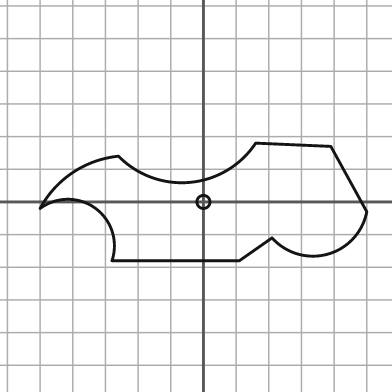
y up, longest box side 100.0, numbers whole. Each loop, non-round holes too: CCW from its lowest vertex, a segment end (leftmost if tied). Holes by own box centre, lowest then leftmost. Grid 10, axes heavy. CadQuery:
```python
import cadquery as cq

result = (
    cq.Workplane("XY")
    .moveTo(-28.0, -18.0)
    .lineTo(11.0, -18.0)
    .lineTo(21.0, -11.0)
    .threePointArc((38.0, -16.0), (50.0, -3.0))
    .lineTo(39.0, 17.0)
    .lineTo(16.0, 18.0)
    .threePointArc((-4.0, 6.0), (-26.0, 14.0))
    .threePointArc((-40.0, 9.0), (-50.0, -2.0))
    .threePointArc((-33.0, -2.0), (-28.0, -18.0))
    .close()
    .moveTo(0.0, 0.0)
    .circle(2.0)
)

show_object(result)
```